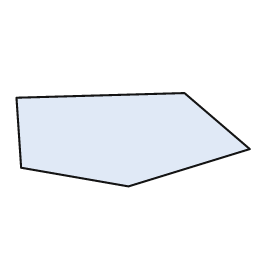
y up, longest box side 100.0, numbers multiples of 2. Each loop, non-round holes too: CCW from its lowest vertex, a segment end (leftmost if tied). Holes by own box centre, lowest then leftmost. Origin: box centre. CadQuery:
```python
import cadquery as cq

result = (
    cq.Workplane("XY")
    .moveTo(-2.0, -20.0)
    .lineTo(50.0, -4.0)
    .lineTo(22.0, 20.0)
    .lineTo(-50.0, 18.0)
    .lineTo(-48.0, -12.0)
    .close()
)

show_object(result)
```